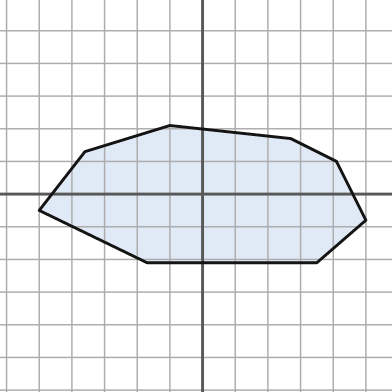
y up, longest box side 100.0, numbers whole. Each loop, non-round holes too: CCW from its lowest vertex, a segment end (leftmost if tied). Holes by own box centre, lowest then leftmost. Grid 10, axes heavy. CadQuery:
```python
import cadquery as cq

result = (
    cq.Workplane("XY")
    .moveTo(-17.0, -21.0)
    .lineTo(35.0, -21.0)
    .lineTo(50.0, -8.0)
    .lineTo(41.0, 10.0)
    .lineTo(27.0, 17.0)
    .lineTo(-10.0, 21.0)
    .lineTo(-36.0, 13.0)
    .lineTo(-50.0, -5.0)
    .close()
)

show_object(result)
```